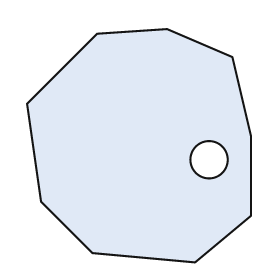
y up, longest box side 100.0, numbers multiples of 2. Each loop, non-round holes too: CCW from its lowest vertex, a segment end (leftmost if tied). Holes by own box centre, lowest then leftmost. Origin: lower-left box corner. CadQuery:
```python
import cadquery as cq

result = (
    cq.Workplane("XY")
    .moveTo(72.0, 0.0)
    .lineTo(96.0, 20.0)
    .lineTo(96.0, 54.0)
    .lineTo(88.0, 88.0)
    .lineTo(60.0, 100.0)
    .lineTo(30.0, 98.0)
    .lineTo(0.0, 68.0)
    .lineTo(6.0, 26.0)
    .lineTo(28.0, 4.0)
    .close()
    .moveTo(78.0, 44.0)
    .circle(8.0)
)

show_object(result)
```